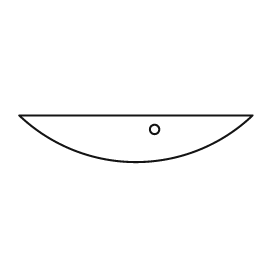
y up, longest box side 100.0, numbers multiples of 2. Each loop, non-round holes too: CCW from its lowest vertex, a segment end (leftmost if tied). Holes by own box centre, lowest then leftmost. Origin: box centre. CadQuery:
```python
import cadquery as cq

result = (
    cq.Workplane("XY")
    .moveTo(-50.0, 10.0)
    .threePointArc((0.0, -10.0), (50.0, 10.0))
    .close()
    .moveTo(8.0, 4.0)
    .circle(2.0)
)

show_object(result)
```